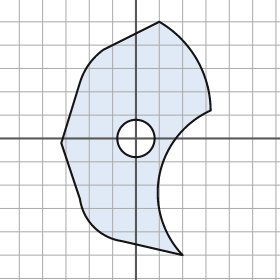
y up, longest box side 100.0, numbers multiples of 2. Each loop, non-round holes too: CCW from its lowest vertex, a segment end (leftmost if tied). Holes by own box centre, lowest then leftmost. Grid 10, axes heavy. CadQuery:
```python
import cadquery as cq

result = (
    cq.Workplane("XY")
    .moveTo(20.0, -50.0)
    .threePointArc((10.0, -16.0), (32.0, 12.0))
    .threePointArc((26.0, 34.0), (10.0, 50.0))
    .lineTo(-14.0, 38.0)
    .threePointArc((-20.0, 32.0), (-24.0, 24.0))
    .lineTo(-32.0, -2.0)
    .lineTo(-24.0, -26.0)
    .threePointArc((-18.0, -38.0), (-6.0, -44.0))
    .close()
    .moveTo(0.0, 0.0)
    .circle(8.0)
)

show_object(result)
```